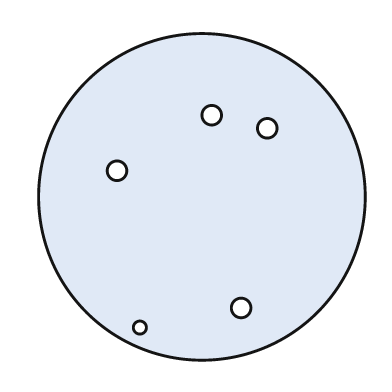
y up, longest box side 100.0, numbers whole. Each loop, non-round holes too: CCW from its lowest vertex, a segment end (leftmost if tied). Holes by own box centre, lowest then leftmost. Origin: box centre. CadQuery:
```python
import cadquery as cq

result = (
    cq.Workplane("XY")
    .moveTo(0.0, 0.0)
    .circle(50.0)
    .moveTo(-19.0, -40.0)
    .circle(2.0)
    .moveTo(12.0, -34.0)
    .circle(3.0)
    .moveTo(-26.0, 8.0)
    .circle(3.0)
    .moveTo(20.0, 21.0)
    .circle(3.0)
    .moveTo(3.0, 25.0)
    .circle(3.0)
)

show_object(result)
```